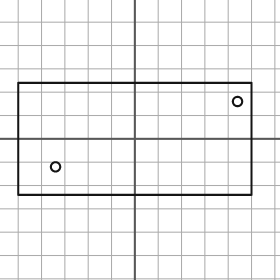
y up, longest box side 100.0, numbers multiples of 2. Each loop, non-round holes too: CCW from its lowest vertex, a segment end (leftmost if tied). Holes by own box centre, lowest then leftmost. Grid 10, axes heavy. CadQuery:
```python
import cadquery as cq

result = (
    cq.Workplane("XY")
    .moveTo(-50.0, -24.0)
    .lineTo(50.0, -24.0)
    .lineTo(50.0, 24.0)
    .lineTo(-50.0, 24.0)
    .close()
    .moveTo(-34.0, -12.0)
    .circle(2.0)
    .moveTo(44.0, 16.0)
    .circle(2.0)
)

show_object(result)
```